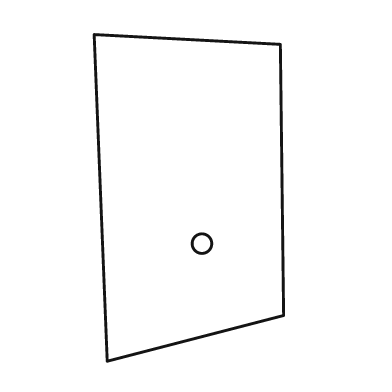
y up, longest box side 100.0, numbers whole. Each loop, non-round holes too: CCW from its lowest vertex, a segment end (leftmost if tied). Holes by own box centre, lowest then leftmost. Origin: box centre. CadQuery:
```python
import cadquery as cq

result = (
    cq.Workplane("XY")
    .moveTo(-25.0, -50.0)
    .lineTo(29.0, -36.0)
    .lineTo(28.0, 47.0)
    .lineTo(-29.0, 50.0)
    .close()
    .moveTo(4.0, -14.0)
    .circle(3.0)
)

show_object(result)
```